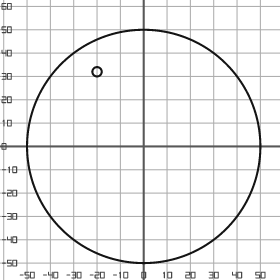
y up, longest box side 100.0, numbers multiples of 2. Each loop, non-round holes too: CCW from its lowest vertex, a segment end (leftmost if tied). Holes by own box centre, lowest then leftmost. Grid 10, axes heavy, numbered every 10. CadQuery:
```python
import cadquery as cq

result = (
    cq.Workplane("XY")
    .moveTo(0.0, 0.0)
    .circle(50.0)
    .moveTo(-20.0, 32.0)
    .circle(2.0)
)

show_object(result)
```